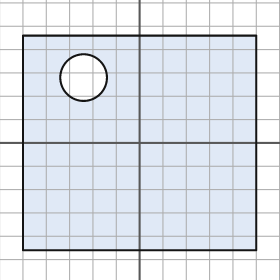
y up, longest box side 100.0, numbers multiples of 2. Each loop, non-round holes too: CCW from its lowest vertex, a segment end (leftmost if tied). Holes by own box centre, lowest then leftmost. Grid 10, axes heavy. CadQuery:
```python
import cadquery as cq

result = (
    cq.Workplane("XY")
    .moveTo(-50.0, -46.0)
    .lineTo(50.0, -46.0)
    .lineTo(50.0, 46.0)
    .lineTo(-50.0, 46.0)
    .close()
    .moveTo(-24.0, 28.0)
    .circle(10.0)
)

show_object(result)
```